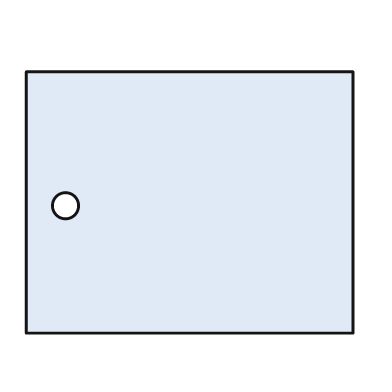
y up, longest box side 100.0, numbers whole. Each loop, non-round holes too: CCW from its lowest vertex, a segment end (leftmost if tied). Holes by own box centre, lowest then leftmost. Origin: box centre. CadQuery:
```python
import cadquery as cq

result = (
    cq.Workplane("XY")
    .moveTo(-50.0, -40.0)
    .lineTo(50.0, -40.0)
    .lineTo(50.0, 40.0)
    .lineTo(-50.0, 40.0)
    .close()
    .moveTo(-38.0, -1.0)
    .circle(4.0)
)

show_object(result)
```